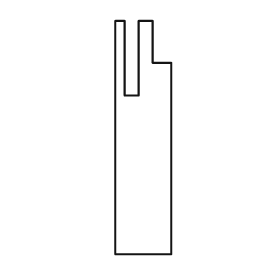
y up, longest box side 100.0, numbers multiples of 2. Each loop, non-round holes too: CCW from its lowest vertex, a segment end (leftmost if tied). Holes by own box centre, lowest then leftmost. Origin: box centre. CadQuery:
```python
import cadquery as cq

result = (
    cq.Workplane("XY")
    .moveTo(-12.0, -50.0)
    .lineTo(12.0, -50.0)
    .lineTo(12.0, 32.0)
    .lineTo(4.0, 32.0)
    .lineTo(4.0, 50.0)
    .lineTo(-2.0, 50.0)
    .lineTo(-2.0, 18.0)
    .lineTo(-8.0, 18.0)
    .lineTo(-8.0, 50.0)
    .lineTo(-12.0, 50.0)
    .close()
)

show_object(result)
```